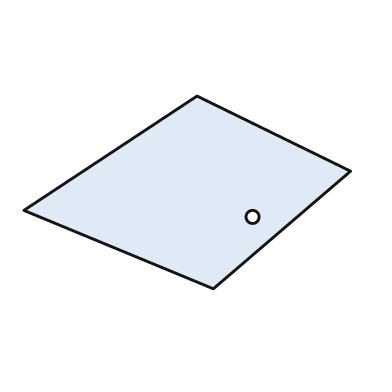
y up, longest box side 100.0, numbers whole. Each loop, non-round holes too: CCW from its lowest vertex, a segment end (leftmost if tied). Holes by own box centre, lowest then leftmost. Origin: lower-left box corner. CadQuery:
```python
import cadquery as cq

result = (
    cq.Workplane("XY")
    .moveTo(58.0, 0.0)
    .lineTo(100.0, 36.0)
    .lineTo(53.0, 59.0)
    .lineTo(0.0, 24.0)
    .close()
    .moveTo(70.0, 22.0)
    .circle(2.0)
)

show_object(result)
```